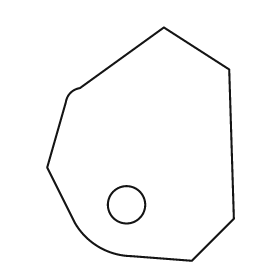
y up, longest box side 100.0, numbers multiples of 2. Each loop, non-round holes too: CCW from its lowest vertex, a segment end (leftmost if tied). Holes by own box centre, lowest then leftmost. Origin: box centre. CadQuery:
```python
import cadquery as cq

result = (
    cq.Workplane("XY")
    .moveTo(22.0, -50.0)
    .lineTo(40.0, -32.0)
    .lineTo(38.0, 32.0)
    .lineTo(10.0, 50.0)
    .lineTo(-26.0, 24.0)
    .threePointArc((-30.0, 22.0), (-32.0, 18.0))
    .lineTo(-40.0, -10.0)
    .lineTo(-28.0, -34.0)
    .threePointArc((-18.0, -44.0), (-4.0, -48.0))
    .close()
    .moveTo(-6.0, -26.0)
    .circle(8.0)
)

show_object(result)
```